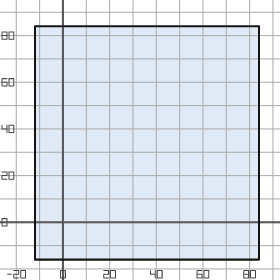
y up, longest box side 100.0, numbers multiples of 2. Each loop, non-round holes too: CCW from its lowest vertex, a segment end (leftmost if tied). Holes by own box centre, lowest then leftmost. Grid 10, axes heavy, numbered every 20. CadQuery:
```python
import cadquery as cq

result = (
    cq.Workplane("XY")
    .moveTo(-12.0, -16.0)
    .lineTo(84.0, -16.0)
    .lineTo(84.0, 84.0)
    .lineTo(-12.0, 84.0)
    .close()
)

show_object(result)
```